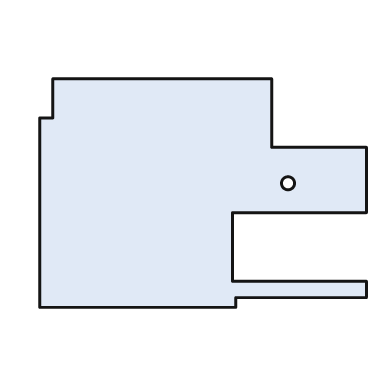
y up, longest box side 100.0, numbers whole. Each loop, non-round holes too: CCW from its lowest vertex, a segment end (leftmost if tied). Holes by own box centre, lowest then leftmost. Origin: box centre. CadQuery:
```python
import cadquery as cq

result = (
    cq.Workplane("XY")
    .moveTo(-50.0, -35.0)
    .lineTo(10.0, -35.0)
    .lineTo(10.0, -32.0)
    .lineTo(50.0, -32.0)
    .lineTo(50.0, -27.0)
    .lineTo(9.0, -27.0)
    .lineTo(9.0, -6.0)
    .lineTo(50.0, -6.0)
    .lineTo(50.0, 14.0)
    .lineTo(21.0, 14.0)
    .lineTo(21.0, 35.0)
    .lineTo(-46.0, 35.0)
    .lineTo(-46.0, 23.0)
    .lineTo(-50.0, 23.0)
    .close()
    .moveTo(26.0, 3.0)
    .circle(2.0)
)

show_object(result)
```